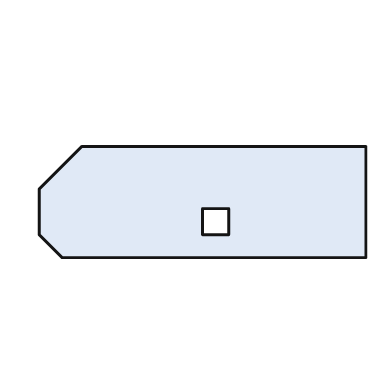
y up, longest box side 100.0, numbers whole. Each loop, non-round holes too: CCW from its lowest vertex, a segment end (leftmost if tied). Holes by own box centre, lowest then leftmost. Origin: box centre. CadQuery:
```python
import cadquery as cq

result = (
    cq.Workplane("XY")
    .moveTo(-43.0, -17.0)
    .lineTo(50.0, -17.0)
    .lineTo(50.0, 17.0)
    .lineTo(-37.0, 17.0)
    .lineTo(-50.0, 4.0)
    .lineTo(-50.0, -10.0)
    .close()
    .moveTo(0.0, -10.0)
    .lineTo(8.0, -10.0)
    .lineTo(8.0, -2.0)
    .lineTo(0.0, -2.0)
    .close()
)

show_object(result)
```